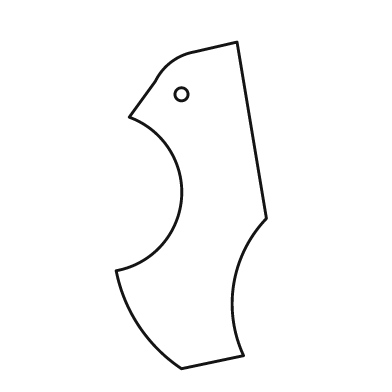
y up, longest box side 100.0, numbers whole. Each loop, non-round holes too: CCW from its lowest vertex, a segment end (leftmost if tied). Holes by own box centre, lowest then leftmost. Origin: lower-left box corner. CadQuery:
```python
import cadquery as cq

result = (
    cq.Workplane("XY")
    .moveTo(20.0, 0.0)
    .lineTo(39.0, 4.0)
    .threePointArc((36.0, 26.0), (46.0, 46.0))
    .lineTo(37.0, 100.0)
    .lineTo(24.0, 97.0)
    .threePointArc((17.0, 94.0), (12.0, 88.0))
    .lineTo(4.0, 77.0)
    .threePointArc((20.0, 52.0), (0.0, 30.0))
    .threePointArc((7.0, 13.0), (20.0, 0.0))
    .close()
    .moveTo(20.0, 84.0)
    .circle(2.0)
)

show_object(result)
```